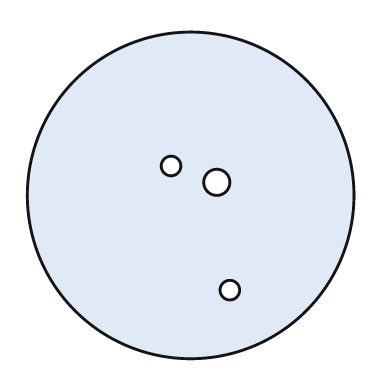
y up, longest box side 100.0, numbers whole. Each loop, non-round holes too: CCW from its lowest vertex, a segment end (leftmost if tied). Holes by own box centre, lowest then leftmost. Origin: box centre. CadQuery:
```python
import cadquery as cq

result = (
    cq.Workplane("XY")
    .moveTo(0.0, 0.0)
    .circle(50.0)
    .moveTo(12.0, -29.0)
    .circle(3.0)
    .moveTo(8.0, 4.0)
    .circle(4.0)
    .moveTo(-6.0, 9.0)
    .circle(3.0)
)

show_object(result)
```